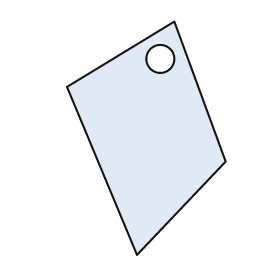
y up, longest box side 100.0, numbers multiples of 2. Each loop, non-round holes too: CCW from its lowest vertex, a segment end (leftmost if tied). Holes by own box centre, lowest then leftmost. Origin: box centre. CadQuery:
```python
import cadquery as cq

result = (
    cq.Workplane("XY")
    .moveTo(-4.0, -50.0)
    .lineTo(34.0, -10.0)
    .lineTo(12.0, 50.0)
    .lineTo(-34.0, 22.0)
    .close()
    .moveTo(6.0, 34.0)
    .circle(6.0)
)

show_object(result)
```